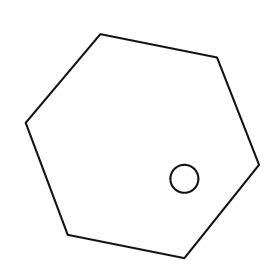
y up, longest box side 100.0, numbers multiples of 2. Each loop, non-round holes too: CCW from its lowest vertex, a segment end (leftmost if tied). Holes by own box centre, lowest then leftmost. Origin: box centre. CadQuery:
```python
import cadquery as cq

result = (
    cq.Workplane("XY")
    .moveTo(18.0, -48.0)
    .lineTo(50.0, -8.0)
    .lineTo(32.0, 38.0)
    .lineTo(-18.0, 48.0)
    .lineTo(-50.0, 10.0)
    .lineTo(-32.0, -38.0)
    .close()
    .moveTo(18.0, -14.0)
    .circle(6.0)
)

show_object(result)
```